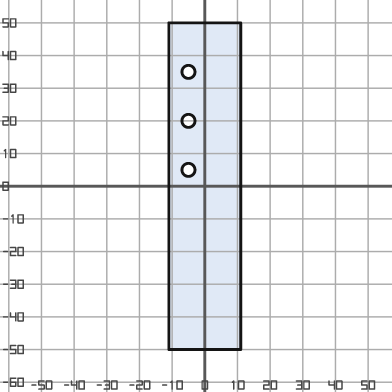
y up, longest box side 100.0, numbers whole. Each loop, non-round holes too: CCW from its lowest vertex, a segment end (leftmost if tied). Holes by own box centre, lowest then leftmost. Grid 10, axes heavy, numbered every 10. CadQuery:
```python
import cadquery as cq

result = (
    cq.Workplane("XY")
    .moveTo(-11.0, -50.0)
    .lineTo(11.0, -50.0)
    .lineTo(11.0, 50.0)
    .lineTo(-11.0, 50.0)
    .close()
    .moveTo(-5.0, 5.0)
    .circle(2.0)
    .moveTo(-5.0, 20.0)
    .circle(2.0)
    .moveTo(-5.0, 35.0)
    .circle(2.0)
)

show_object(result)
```